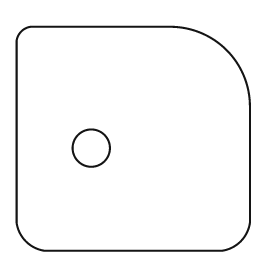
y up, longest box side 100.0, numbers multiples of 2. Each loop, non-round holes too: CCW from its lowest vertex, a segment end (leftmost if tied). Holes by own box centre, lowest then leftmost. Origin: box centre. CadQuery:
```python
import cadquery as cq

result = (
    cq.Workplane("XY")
    .moveTo(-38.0, -48.0)
    .lineTo(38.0, -48.0)
    .threePointArc((46.0, -44.0), (50.0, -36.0))
    .lineTo(50.0, 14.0)
    .threePointArc((40.0, 38.0), (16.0, 48.0))
    .lineTo(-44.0, 48.0)
    .threePointArc((-48.0, 46.0), (-50.0, 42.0))
    .lineTo(-50.0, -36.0)
    .threePointArc((-46.0, -44.0), (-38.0, -48.0))
    .close()
    .moveTo(-18.0, -4.0)
    .circle(8.0)
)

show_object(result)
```